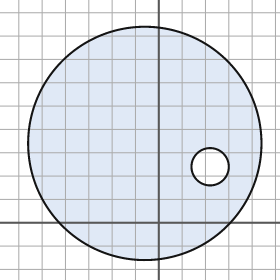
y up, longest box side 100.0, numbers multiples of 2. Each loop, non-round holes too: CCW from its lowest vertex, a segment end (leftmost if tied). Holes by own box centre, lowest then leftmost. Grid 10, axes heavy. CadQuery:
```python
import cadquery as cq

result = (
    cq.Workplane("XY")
    .moveTo(-6.0, 34.0)
    .circle(50.0)
    .moveTo(22.0, 24.0)
    .circle(8.0)
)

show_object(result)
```